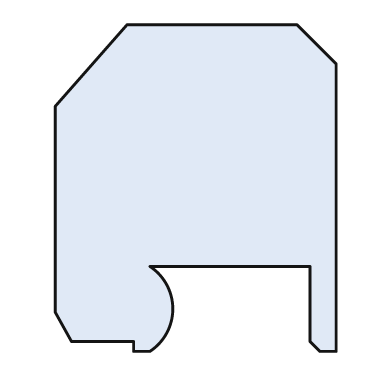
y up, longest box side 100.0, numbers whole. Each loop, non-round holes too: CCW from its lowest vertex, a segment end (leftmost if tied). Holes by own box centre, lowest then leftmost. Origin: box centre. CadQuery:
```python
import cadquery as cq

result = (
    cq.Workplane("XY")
    .moveTo(-19.0, -50.0)
    .lineTo(-14.0, -50.0)
    .threePointArc((-7.0, -37.0), (-14.0, -24.0))
    .lineTo(35.0, -24.0)
    .lineTo(35.0, -47.0)
    .lineTo(38.0, -50.0)
    .lineTo(43.0, -50.0)
    .lineTo(43.0, 38.0)
    .lineTo(31.0, 50.0)
    .lineTo(-21.0, 50.0)
    .lineTo(-43.0, 25.0)
    .lineTo(-43.0, -38.0)
    .lineTo(-38.0, -47.0)
    .lineTo(-19.0, -47.0)
    .close()
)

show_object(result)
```